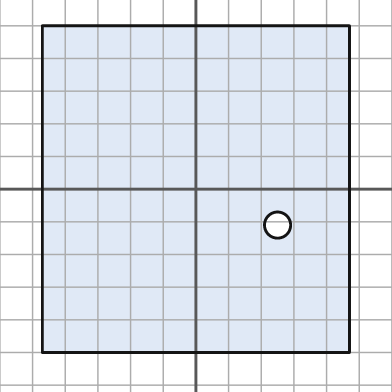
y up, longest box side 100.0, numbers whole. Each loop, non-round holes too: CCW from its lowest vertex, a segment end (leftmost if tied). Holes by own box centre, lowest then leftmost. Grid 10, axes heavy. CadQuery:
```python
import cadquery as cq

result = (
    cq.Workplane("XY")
    .moveTo(-47.0, -50.0)
    .lineTo(47.0, -50.0)
    .lineTo(47.0, 50.0)
    .lineTo(-47.0, 50.0)
    .close()
    .moveTo(25.0, -11.0)
    .circle(4.0)
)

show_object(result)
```